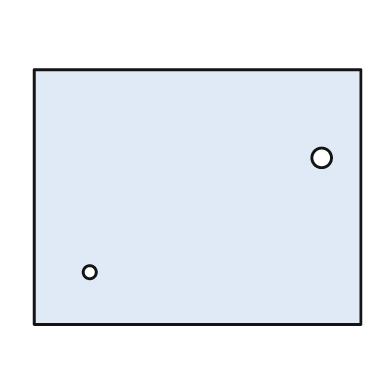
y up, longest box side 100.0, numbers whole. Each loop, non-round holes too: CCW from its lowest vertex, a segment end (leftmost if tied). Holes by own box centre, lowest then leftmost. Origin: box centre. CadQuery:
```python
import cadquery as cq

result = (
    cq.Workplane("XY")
    .moveTo(-50.0, -39.0)
    .lineTo(50.0, -39.0)
    .lineTo(50.0, 39.0)
    .lineTo(-50.0, 39.0)
    .close()
    .moveTo(-33.0, -23.0)
    .circle(2.0)
    .moveTo(38.0, 12.0)
    .circle(3.0)
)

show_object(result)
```